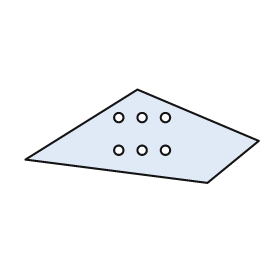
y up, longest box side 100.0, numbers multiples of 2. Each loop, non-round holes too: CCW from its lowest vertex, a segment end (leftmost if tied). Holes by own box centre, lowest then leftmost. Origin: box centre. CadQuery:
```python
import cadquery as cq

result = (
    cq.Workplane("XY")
    .moveTo(28.0, -20.0)
    .lineTo(50.0, -2.0)
    .lineTo(-2.0, 20.0)
    .lineTo(-50.0, -10.0)
    .close()
    .moveTo(-10.0, -6.0)
    .circle(2.0)
    .moveTo(0.0, -6.0)
    .circle(2.0)
    .moveTo(10.0, -6.0)
    .circle(2.0)
    .moveTo(-10.0, 8.0)
    .circle(2.0)
    .moveTo(0.0, 8.0)
    .circle(2.0)
    .moveTo(10.0, 8.0)
    .circle(2.0)
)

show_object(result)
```